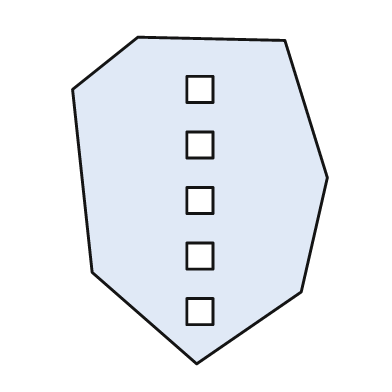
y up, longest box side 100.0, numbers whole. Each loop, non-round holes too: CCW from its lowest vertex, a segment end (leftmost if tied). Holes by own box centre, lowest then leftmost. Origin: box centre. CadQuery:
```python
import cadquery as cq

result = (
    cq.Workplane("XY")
    .moveTo(-1.0, -50.0)
    .lineTo(31.0, -28.0)
    .lineTo(39.0, 7.0)
    .lineTo(26.0, 49.0)
    .lineTo(-19.0, 50.0)
    .lineTo(-39.0, 34.0)
    .lineTo(-33.0, -22.0)
    .close()
    .moveTo(-4.0, -38.0)
    .lineTo(4.0, -38.0)
    .lineTo(4.0, -30.0)
    .lineTo(-4.0, -30.0)
    .close()
    .moveTo(-4.0, -21.0)
    .lineTo(4.0, -21.0)
    .lineTo(4.0, -13.0)
    .lineTo(-4.0, -13.0)
    .close()
    .moveTo(-4.0, -4.0)
    .lineTo(4.0, -4.0)
    .lineTo(4.0, 4.0)
    .lineTo(-4.0, 4.0)
    .close()
    .moveTo(-4.0, 13.0)
    .lineTo(4.0, 13.0)
    .lineTo(4.0, 21.0)
    .lineTo(-4.0, 21.0)
    .close()
    .moveTo(-4.0, 30.0)
    .lineTo(4.0, 30.0)
    .lineTo(4.0, 38.0)
    .lineTo(-4.0, 38.0)
    .close()
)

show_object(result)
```